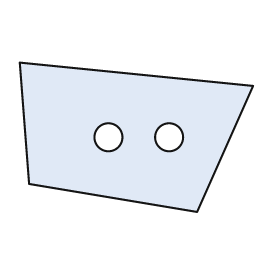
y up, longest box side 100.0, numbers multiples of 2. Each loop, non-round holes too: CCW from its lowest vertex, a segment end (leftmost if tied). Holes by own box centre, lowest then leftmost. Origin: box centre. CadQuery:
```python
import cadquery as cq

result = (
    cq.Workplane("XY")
    .moveTo(26.0, -32.0)
    .lineTo(50.0, 22.0)
    .lineTo(-50.0, 32.0)
    .lineTo(-46.0, -20.0)
    .close()
    .moveTo(-12.0, 0.0)
    .circle(6.0)
    .moveTo(14.0, 0.0)
    .circle(6.0)
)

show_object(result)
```